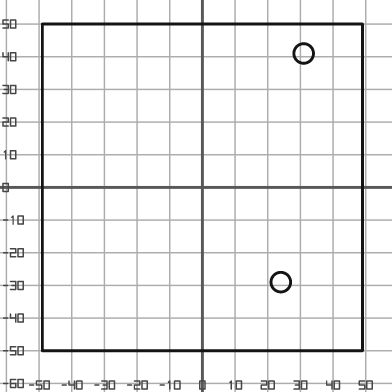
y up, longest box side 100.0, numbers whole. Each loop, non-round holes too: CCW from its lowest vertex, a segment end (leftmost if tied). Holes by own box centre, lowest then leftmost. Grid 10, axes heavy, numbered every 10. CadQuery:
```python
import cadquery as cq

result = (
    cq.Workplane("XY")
    .moveTo(-49.0, -50.0)
    .lineTo(49.0, -50.0)
    .lineTo(49.0, 50.0)
    .lineTo(-49.0, 50.0)
    .close()
    .moveTo(24.0, -29.0)
    .circle(3.0)
    .moveTo(31.0, 41.0)
    .circle(3.0)
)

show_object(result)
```